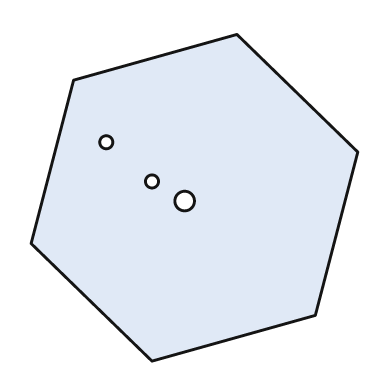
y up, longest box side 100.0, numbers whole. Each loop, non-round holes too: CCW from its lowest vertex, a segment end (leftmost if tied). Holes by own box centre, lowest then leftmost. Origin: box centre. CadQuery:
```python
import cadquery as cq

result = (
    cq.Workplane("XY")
    .moveTo(-13.0, -50.0)
    .lineTo(37.0, -36.0)
    .lineTo(50.0, 14.0)
    .lineTo(13.0, 50.0)
    .lineTo(-37.0, 36.0)
    .lineTo(-50.0, -14.0)
    .close()
    .moveTo(-3.0, -1.0)
    .circle(3.0)
    .moveTo(-13.0, 5.0)
    .circle(2.0)
    .moveTo(-27.0, 17.0)
    .circle(2.0)
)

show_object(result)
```